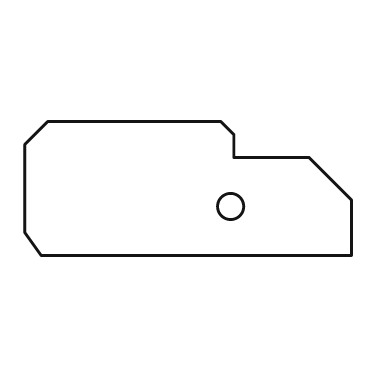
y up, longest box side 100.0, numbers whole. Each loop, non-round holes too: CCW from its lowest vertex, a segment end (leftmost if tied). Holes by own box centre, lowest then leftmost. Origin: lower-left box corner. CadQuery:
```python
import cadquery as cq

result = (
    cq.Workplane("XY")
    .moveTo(5.0, 0.0)
    .lineTo(100.0, 0.0)
    .lineTo(100.0, 17.0)
    .lineTo(87.0, 30.0)
    .lineTo(64.0, 30.0)
    .lineTo(64.0, 37.0)
    .lineTo(60.0, 41.0)
    .lineTo(7.0, 41.0)
    .lineTo(0.0, 34.0)
    .lineTo(0.0, 7.0)
    .close()
    .moveTo(63.0, 15.0)
    .circle(4.0)
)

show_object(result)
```